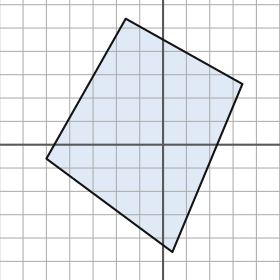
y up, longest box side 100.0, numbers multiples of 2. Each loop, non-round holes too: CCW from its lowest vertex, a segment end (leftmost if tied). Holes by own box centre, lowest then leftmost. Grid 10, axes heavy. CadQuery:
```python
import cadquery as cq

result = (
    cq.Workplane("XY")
    .moveTo(4.0, -46.0)
    .lineTo(34.0, 26.0)
    .lineTo(-16.0, 54.0)
    .lineTo(-50.0, -6.0)
    .close()
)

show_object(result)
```